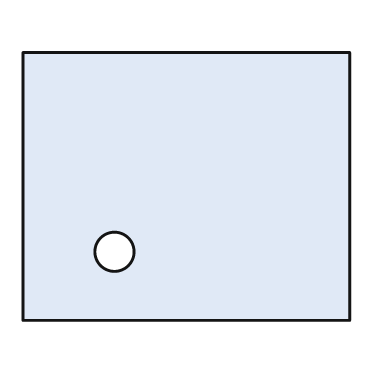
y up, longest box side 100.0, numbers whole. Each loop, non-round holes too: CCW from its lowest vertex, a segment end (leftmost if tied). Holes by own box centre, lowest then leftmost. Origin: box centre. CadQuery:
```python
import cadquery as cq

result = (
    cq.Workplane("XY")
    .moveTo(-50.0, -41.0)
    .lineTo(50.0, -41.0)
    .lineTo(50.0, 41.0)
    .lineTo(-50.0, 41.0)
    .close()
    .moveTo(-22.0, -20.0)
    .circle(6.0)
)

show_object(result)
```